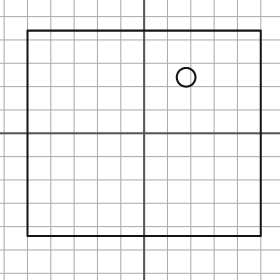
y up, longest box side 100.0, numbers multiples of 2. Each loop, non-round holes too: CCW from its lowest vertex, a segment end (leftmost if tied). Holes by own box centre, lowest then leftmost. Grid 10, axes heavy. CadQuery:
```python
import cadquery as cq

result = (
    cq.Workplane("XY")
    .moveTo(-50.0, -44.0)
    .lineTo(50.0, -44.0)
    .lineTo(50.0, 44.0)
    .lineTo(-50.0, 44.0)
    .close()
    .moveTo(18.0, 24.0)
    .circle(4.0)
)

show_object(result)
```